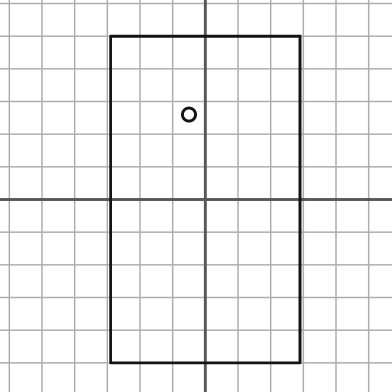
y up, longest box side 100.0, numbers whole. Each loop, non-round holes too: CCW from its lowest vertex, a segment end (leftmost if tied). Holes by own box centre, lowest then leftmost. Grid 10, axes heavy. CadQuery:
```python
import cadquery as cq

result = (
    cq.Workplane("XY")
    .moveTo(-29.0, -50.0)
    .lineTo(29.0, -50.0)
    .lineTo(29.0, 50.0)
    .lineTo(-29.0, 50.0)
    .close()
    .moveTo(-5.0, 26.0)
    .circle(2.0)
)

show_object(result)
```